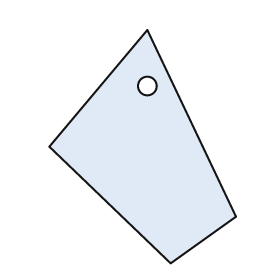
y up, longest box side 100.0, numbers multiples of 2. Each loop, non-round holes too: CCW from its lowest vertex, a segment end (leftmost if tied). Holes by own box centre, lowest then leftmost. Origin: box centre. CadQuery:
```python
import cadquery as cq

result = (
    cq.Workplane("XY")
    .moveTo(12.0, -50.0)
    .lineTo(40.0, -30.0)
    .lineTo(2.0, 50.0)
    .lineTo(-40.0, 0.0)
    .close()
    .moveTo(2.0, 26.0)
    .circle(4.0)
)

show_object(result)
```